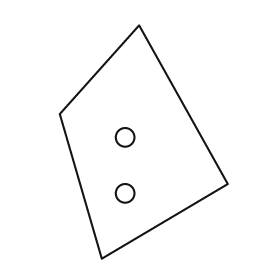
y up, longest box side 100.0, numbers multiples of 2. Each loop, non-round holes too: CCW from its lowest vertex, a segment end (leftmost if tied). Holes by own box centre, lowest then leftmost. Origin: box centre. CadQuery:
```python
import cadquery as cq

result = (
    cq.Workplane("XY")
    .moveTo(-18.0, -50.0)
    .lineTo(36.0, -18.0)
    .lineTo(-2.0, 50.0)
    .lineTo(-36.0, 12.0)
    .close()
    .moveTo(-8.0, -22.0)
    .circle(4.0)
    .moveTo(-8.0, 2.0)
    .circle(4.0)
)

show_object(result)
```